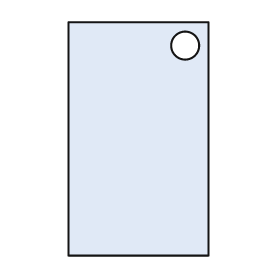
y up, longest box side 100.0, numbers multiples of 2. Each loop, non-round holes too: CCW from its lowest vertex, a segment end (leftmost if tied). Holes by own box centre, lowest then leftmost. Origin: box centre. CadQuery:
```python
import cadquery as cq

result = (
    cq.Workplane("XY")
    .moveTo(-30.0, -50.0)
    .lineTo(30.0, -50.0)
    .lineTo(30.0, 50.0)
    .lineTo(-30.0, 50.0)
    .close()
    .moveTo(20.0, 40.0)
    .circle(6.0)
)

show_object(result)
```